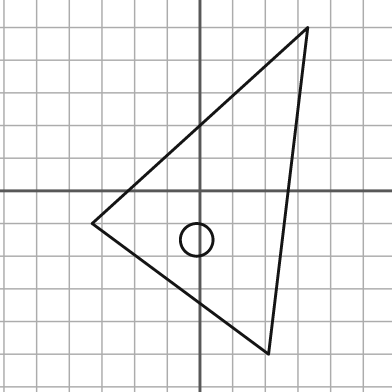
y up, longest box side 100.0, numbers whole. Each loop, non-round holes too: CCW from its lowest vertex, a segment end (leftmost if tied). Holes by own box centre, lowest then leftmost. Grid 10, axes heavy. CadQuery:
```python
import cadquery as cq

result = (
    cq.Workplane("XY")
    .moveTo(21.0, -50.0)
    .lineTo(33.0, 50.0)
    .lineTo(-33.0, -10.0)
    .close()
    .moveTo(-1.0, -15.0)
    .circle(5.0)
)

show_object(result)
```